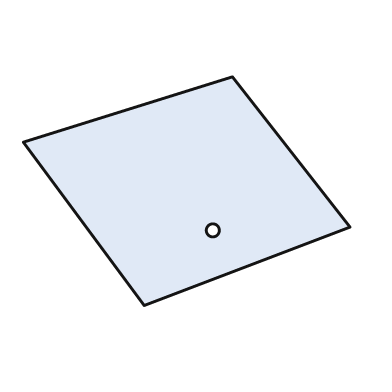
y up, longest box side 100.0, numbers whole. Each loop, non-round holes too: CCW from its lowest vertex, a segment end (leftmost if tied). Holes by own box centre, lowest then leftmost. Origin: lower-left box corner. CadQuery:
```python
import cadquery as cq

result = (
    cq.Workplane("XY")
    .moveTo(37.0, 0.0)
    .lineTo(100.0, 24.0)
    .lineTo(64.0, 70.0)
    .lineTo(0.0, 50.0)
    .close()
    .moveTo(58.0, 23.0)
    .circle(2.0)
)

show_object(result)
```